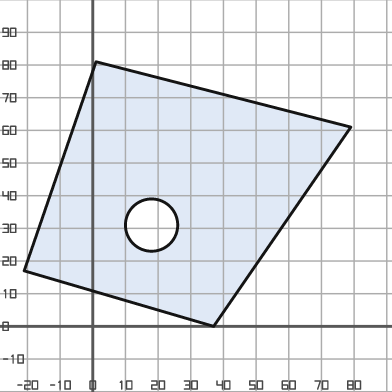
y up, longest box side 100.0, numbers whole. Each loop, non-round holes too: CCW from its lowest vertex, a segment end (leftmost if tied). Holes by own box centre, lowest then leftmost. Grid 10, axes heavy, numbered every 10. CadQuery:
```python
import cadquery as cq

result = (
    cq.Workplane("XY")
    .moveTo(37.0, 0.0)
    .lineTo(79.0, 61.0)
    .lineTo(1.0, 81.0)
    .lineTo(-21.0, 17.0)
    .close()
    .moveTo(18.0, 31.0)
    .circle(8.0)
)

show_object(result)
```